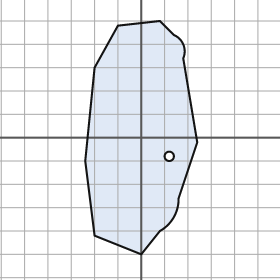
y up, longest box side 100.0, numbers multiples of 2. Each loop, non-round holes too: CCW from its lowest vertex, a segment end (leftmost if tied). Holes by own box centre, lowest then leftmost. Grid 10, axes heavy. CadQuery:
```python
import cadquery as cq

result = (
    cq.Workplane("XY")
    .moveTo(0.0, -50.0)
    .lineTo(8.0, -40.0)
    .threePointArc((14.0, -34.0), (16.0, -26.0))
    .lineTo(24.0, -2.0)
    .lineTo(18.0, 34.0)
    .threePointArc((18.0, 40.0), (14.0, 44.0))
    .lineTo(8.0, 50.0)
    .lineTo(-10.0, 48.0)
    .lineTo(-20.0, 30.0)
    .lineTo(-24.0, -10.0)
    .lineTo(-20.0, -42.0)
    .close()
    .moveTo(12.0, -8.0)
    .circle(2.0)
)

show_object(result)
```